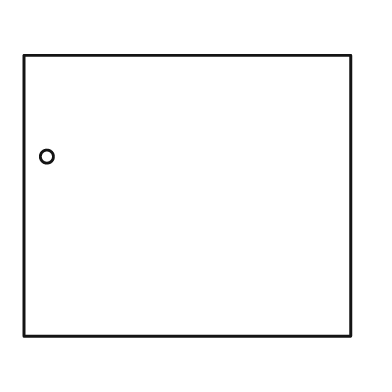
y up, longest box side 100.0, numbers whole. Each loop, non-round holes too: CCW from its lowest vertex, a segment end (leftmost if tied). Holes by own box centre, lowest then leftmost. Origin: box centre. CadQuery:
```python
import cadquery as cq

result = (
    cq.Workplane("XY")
    .moveTo(-50.0, -43.0)
    .lineTo(50.0, -43.0)
    .lineTo(50.0, 43.0)
    .lineTo(-50.0, 43.0)
    .close()
    .moveTo(-43.0, 12.0)
    .circle(2.0)
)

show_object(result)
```